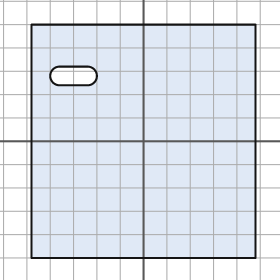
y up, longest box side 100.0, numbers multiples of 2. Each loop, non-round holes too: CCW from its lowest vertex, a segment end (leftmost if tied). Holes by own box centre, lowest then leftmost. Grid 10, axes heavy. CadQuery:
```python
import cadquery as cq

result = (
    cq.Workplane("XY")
    .moveTo(-48.0, -50.0)
    .lineTo(48.0, -50.0)
    .lineTo(48.0, 50.0)
    .lineTo(-48.0, 50.0)
    .close()
    .moveTo(-36.0, 24.0)
    .lineTo(-24.0, 24.0)
    .threePointArc((-20.0, 28.0), (-24.0, 32.0))
    .lineTo(-36.0, 32.0)
    .threePointArc((-40.0, 28.0), (-36.0, 24.0))
    .close()
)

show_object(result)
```